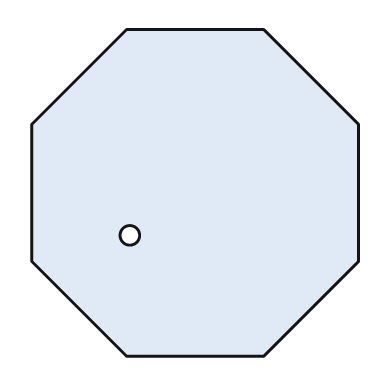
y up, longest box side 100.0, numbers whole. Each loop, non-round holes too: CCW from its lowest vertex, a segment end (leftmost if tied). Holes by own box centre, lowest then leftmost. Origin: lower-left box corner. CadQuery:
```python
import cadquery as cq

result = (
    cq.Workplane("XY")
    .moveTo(29.0, 0.0)
    .lineTo(71.0, 0.0)
    .lineTo(100.0, 29.0)
    .lineTo(100.0, 71.0)
    .lineTo(71.0, 100.0)
    .lineTo(29.0, 100.0)
    .lineTo(0.0, 71.0)
    .lineTo(0.0, 29.0)
    .close()
    .moveTo(30.0, 37.0)
    .circle(3.0)
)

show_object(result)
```